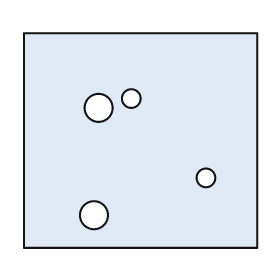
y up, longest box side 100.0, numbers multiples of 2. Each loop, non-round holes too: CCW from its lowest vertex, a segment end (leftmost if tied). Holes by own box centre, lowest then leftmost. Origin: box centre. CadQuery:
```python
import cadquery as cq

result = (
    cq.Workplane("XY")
    .moveTo(-50.0, -46.0)
    .lineTo(50.0, -46.0)
    .lineTo(50.0, 46.0)
    .lineTo(-50.0, 46.0)
    .close()
    .moveTo(-20.0, -32.0)
    .circle(6.0)
    .moveTo(28.0, -16.0)
    .circle(4.0)
    .moveTo(-18.0, 14.0)
    .circle(6.0)
    .moveTo(-4.0, 18.0)
    .circle(4.0)
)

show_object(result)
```